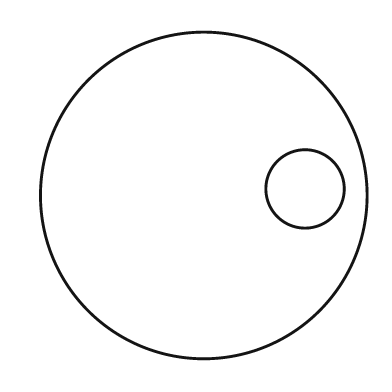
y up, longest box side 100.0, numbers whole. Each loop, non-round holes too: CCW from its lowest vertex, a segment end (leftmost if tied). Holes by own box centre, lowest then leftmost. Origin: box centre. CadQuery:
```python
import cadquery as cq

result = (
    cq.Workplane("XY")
    .moveTo(0.0, 0.0)
    .circle(50.0)
    .moveTo(31.0, 2.0)
    .circle(12.0)
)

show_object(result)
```